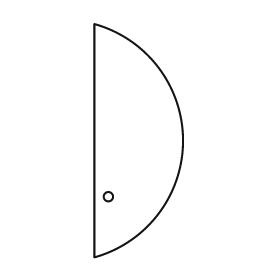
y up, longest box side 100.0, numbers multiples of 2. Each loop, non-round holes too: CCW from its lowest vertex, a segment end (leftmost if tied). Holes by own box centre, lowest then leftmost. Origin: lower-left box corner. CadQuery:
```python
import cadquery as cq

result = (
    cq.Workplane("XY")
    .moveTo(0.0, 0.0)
    .threePointArc((38.0, 50.0), (0.0, 100.0))
    .close()
    .moveTo(6.0, 26.0)
    .circle(2.0)
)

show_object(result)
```